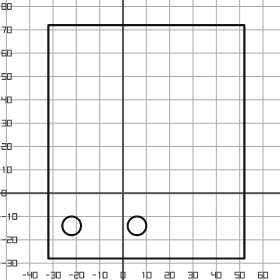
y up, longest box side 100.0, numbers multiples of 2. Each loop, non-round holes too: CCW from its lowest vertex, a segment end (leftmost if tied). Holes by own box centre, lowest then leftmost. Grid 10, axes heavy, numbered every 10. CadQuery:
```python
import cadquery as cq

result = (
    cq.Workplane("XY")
    .moveTo(-32.0, -28.0)
    .lineTo(52.0, -28.0)
    .lineTo(52.0, 72.0)
    .lineTo(-32.0, 72.0)
    .close()
    .moveTo(-22.0, -14.0)
    .circle(4.0)
    .moveTo(6.0, -14.0)
    .circle(4.0)
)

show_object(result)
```